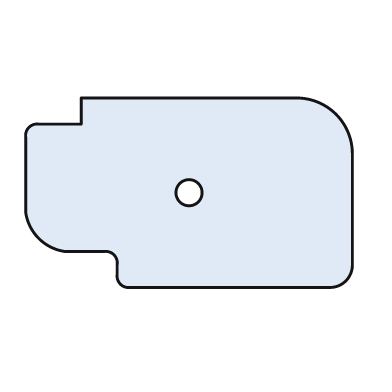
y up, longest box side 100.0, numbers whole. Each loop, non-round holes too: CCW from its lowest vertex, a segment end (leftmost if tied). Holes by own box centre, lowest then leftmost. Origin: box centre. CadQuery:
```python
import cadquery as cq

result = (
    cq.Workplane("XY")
    .moveTo(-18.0, -29.0)
    .lineTo(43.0, -29.0)
    .threePointArc((48.0, -27.0), (50.0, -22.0))
    .lineTo(50.0, 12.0)
    .threePointArc((45.0, 24.0), (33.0, 29.0))
    .lineTo(-33.0, 29.0)
    .lineTo(-33.0, 21.0)
    .lineTo(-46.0, 21.0)
    .threePointArc((-49.0, 20.0), (-50.0, 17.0))
    .lineTo(-50.0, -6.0)
    .threePointArc((-46.0, -14.0), (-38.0, -18.0))
    .lineTo(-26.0, -18.0)
    .threePointArc((-23.0, -19.0), (-22.0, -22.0))
    .lineTo(-22.0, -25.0)
    .threePointArc((-21.0, -28.0), (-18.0, -29.0))
    .close()
    .moveTo(0.0, 0.0)
    .circle(4.0)
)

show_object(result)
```